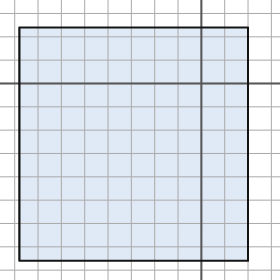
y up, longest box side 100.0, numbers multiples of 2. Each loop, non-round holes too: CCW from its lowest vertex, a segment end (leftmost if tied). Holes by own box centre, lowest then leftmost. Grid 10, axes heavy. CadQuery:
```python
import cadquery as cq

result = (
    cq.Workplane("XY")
    .moveTo(-78.0, -76.0)
    .lineTo(20.0, -76.0)
    .lineTo(20.0, 24.0)
    .lineTo(-78.0, 24.0)
    .close()
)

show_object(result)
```